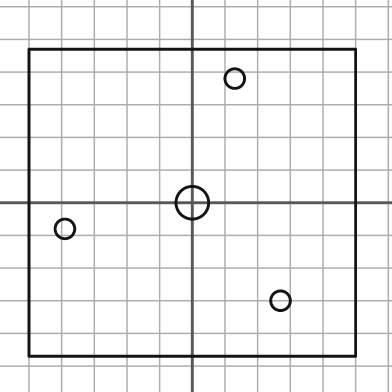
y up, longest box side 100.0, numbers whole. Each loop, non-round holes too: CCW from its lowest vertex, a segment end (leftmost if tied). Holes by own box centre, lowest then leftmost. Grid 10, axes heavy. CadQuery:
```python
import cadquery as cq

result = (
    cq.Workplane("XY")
    .moveTo(-50.0, -47.0)
    .lineTo(50.0, -47.0)
    .lineTo(50.0, 47.0)
    .lineTo(-50.0, 47.0)
    .close()
    .moveTo(27.0, -30.0)
    .circle(3.0)
    .moveTo(-39.0, -8.0)
    .circle(3.0)
    .moveTo(0.0, 0.0)
    .circle(5.0)
    .moveTo(13.0, 38.0)
    .circle(3.0)
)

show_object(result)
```